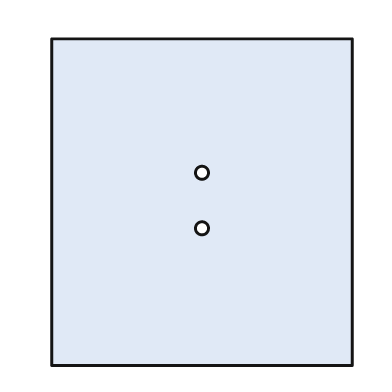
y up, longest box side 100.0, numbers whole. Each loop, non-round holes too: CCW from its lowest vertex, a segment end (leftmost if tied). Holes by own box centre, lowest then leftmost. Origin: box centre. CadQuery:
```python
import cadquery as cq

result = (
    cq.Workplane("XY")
    .moveTo(-46.0, -50.0)
    .lineTo(46.0, -50.0)
    .lineTo(46.0, 50.0)
    .lineTo(-46.0, 50.0)
    .close()
    .moveTo(0.0, -8.0)
    .circle(2.0)
    .moveTo(0.0, 9.0)
    .circle(2.0)
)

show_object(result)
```